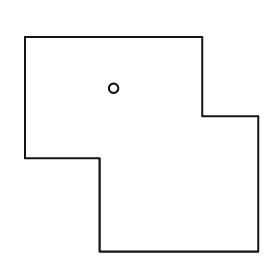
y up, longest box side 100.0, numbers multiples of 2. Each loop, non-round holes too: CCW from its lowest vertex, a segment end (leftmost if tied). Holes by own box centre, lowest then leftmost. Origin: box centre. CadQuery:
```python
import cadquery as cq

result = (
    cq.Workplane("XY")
    .moveTo(-18.0, -46.0)
    .lineTo(50.0, -46.0)
    .lineTo(50.0, 12.0)
    .lineTo(26.0, 12.0)
    .lineTo(26.0, 46.0)
    .lineTo(-50.0, 46.0)
    .lineTo(-50.0, -6.0)
    .lineTo(-18.0, -6.0)
    .close()
    .moveTo(-12.0, 24.0)
    .circle(2.0)
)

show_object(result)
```